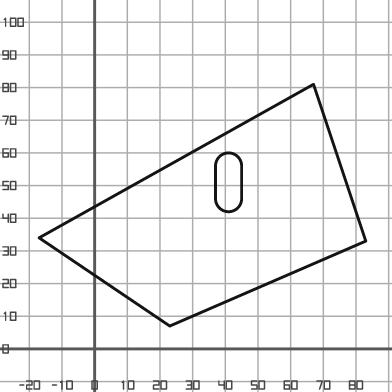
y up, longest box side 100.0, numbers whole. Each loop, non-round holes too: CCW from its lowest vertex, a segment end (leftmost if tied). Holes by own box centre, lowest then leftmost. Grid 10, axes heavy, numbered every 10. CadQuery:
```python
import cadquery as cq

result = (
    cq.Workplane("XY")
    .moveTo(23.0, 7.0)
    .lineTo(83.0, 33.0)
    .lineTo(67.0, 81.0)
    .lineTo(-17.0, 34.0)
    .close()
    .moveTo(37.0, 46.0)
    .threePointArc((41.0, 42.0), (45.0, 46.0))
    .lineTo(45.0, 56.0)
    .threePointArc((41.0, 60.0), (37.0, 56.0))
    .close()
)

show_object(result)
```